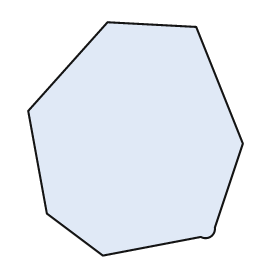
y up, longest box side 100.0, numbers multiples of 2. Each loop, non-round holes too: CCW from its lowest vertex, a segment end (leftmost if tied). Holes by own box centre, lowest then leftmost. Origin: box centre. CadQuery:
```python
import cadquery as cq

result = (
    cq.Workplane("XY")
    .moveTo(-14.0, -50.0)
    .lineTo(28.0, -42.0)
    .threePointArc((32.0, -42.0), (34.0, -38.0))
    .lineTo(46.0, -2.0)
    .lineTo(26.0, 48.0)
    .lineTo(-12.0, 50.0)
    .lineTo(-46.0, 12.0)
    .lineTo(-38.0, -32.0)
    .close()
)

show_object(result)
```